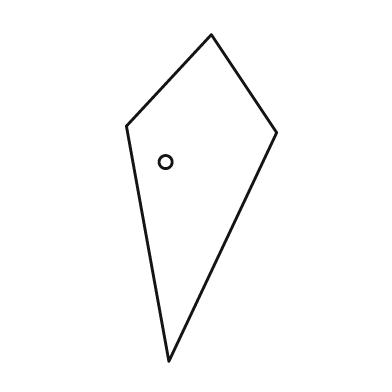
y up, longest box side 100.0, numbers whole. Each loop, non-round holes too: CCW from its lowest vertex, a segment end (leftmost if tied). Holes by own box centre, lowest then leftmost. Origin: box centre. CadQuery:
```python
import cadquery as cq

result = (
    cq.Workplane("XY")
    .moveTo(-10.0, -50.0)
    .lineTo(23.0, 20.0)
    .lineTo(3.0, 50.0)
    .lineTo(-23.0, 22.0)
    .close()
    .moveTo(-11.0, 11.0)
    .circle(2.0)
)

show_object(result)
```